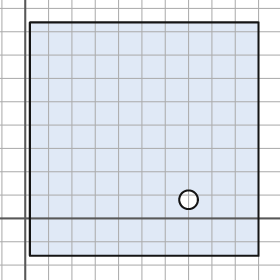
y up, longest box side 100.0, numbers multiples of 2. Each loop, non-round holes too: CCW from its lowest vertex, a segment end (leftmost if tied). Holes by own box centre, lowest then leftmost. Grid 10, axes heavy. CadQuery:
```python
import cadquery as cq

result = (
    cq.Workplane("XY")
    .moveTo(2.0, -16.0)
    .lineTo(100.0, -16.0)
    .lineTo(100.0, 84.0)
    .lineTo(2.0, 84.0)
    .close()
    .moveTo(70.0, 8.0)
    .circle(4.0)
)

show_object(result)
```